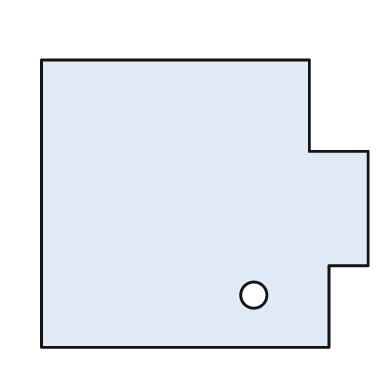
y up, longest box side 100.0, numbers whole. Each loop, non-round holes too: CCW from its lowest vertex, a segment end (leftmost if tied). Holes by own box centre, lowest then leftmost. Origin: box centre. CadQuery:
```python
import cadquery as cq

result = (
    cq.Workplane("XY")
    .moveTo(-50.0, -44.0)
    .lineTo(38.0, -44.0)
    .lineTo(38.0, -19.0)
    .lineTo(50.0, -19.0)
    .lineTo(50.0, 16.0)
    .lineTo(32.0, 16.0)
    .lineTo(32.0, 44.0)
    .lineTo(-50.0, 44.0)
    .close()
    .moveTo(15.0, -28.0)
    .circle(4.0)
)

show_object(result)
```